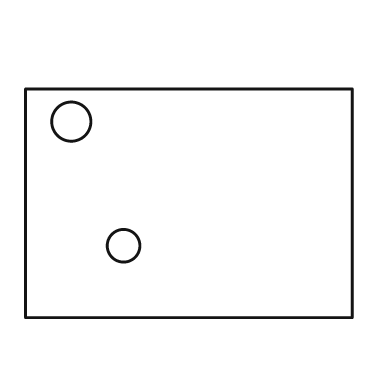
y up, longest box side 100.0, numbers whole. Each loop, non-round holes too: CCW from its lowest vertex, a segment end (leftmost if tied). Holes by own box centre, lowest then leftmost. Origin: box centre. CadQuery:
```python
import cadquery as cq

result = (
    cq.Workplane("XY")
    .moveTo(-50.0, -35.0)
    .lineTo(50.0, -35.0)
    .lineTo(50.0, 35.0)
    .lineTo(-50.0, 35.0)
    .close()
    .moveTo(-20.0, -13.0)
    .circle(5.0)
    .moveTo(-36.0, 25.0)
    .circle(6.0)
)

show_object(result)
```